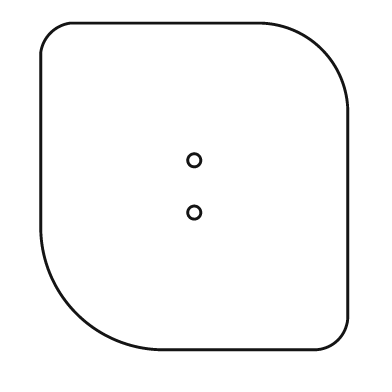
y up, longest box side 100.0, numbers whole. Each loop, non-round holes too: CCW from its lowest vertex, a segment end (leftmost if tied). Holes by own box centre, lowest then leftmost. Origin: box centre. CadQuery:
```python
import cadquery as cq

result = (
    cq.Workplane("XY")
    .moveTo(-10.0, -50.0)
    .lineTo(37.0, -50.0)
    .threePointArc((44.0, -47.0), (47.0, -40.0))
    .lineTo(47.0, 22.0)
    .threePointArc((39.0, 42.0), (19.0, 50.0))
    .lineTo(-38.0, 50.0)
    .threePointArc((-44.0, 47.0), (-47.0, 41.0))
    .lineTo(-47.0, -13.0)
    .threePointArc((-36.0, -39.0), (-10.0, -50.0))
    .close()
    .moveTo(0.0, -8.0)
    .circle(2.0)
    .moveTo(0.0, 8.0)
    .circle(2.0)
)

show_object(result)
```